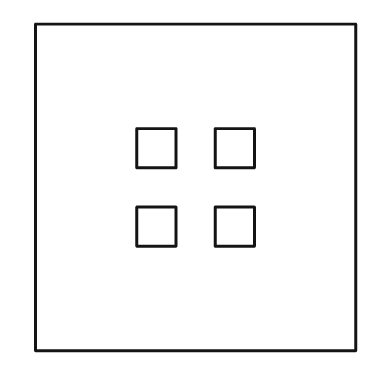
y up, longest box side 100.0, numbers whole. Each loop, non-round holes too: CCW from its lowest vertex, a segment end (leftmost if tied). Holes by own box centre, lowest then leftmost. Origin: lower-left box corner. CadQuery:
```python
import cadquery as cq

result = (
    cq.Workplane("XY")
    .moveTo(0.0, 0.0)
    .lineTo(98.0, 0.0)
    .lineTo(98.0, 100.0)
    .lineTo(0.0, 100.0)
    .close()
    .moveTo(31.0, 32.0)
    .lineTo(43.0, 32.0)
    .lineTo(43.0, 44.0)
    .lineTo(31.0, 44.0)
    .close()
    .moveTo(55.0, 32.0)
    .lineTo(67.0, 32.0)
    .lineTo(67.0, 44.0)
    .lineTo(55.0, 44.0)
    .close()
    .moveTo(31.0, 56.0)
    .lineTo(43.0, 56.0)
    .lineTo(43.0, 68.0)
    .lineTo(31.0, 68.0)
    .close()
    .moveTo(55.0, 56.0)
    .lineTo(67.0, 56.0)
    .lineTo(67.0, 68.0)
    .lineTo(55.0, 68.0)
    .close()
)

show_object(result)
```